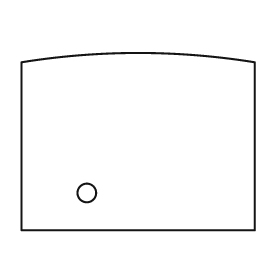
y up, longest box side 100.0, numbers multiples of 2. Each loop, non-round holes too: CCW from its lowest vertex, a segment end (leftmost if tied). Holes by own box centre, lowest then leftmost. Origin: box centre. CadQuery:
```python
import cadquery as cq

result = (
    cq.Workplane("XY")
    .moveTo(-50.0, -38.0)
    .lineTo(50.0, -38.0)
    .lineTo(50.0, 34.0)
    .threePointArc((0.0, 38.0), (-50.0, 34.0))
    .close()
    .moveTo(-22.0, -22.0)
    .circle(4.0)
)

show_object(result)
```